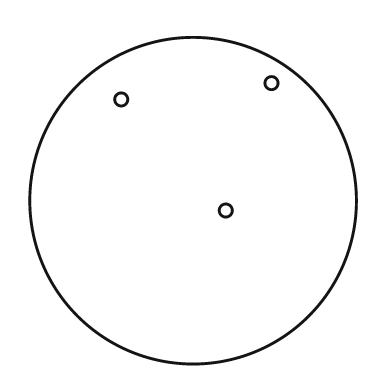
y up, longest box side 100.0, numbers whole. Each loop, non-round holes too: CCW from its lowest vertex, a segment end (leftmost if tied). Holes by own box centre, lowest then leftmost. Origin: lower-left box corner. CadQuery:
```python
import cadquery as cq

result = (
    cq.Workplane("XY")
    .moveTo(50.0, 50.0)
    .circle(50.0)
    .moveTo(60.0, 47.0)
    .circle(2.0)
    .moveTo(28.0, 81.0)
    .circle(2.0)
    .moveTo(74.0, 86.0)
    .circle(2.0)
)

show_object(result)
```